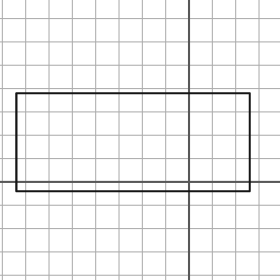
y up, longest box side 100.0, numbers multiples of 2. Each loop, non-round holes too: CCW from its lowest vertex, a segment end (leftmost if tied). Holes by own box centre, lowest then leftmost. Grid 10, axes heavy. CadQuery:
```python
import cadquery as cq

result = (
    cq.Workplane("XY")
    .moveTo(-74.0, -4.0)
    .lineTo(26.0, -4.0)
    .lineTo(26.0, 38.0)
    .lineTo(-74.0, 38.0)
    .close()
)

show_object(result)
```